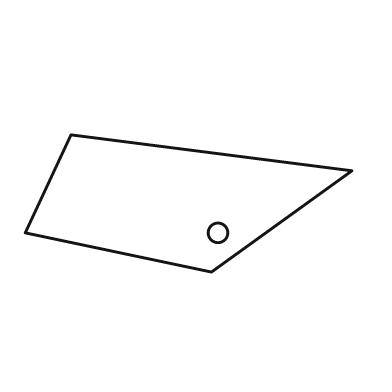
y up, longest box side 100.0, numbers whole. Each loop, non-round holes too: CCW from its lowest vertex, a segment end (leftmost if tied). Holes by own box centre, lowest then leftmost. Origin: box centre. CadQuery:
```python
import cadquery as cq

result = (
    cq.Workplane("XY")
    .moveTo(7.0, -21.0)
    .lineTo(50.0, 10.0)
    .lineTo(-36.0, 21.0)
    .lineTo(-50.0, -9.0)
    .close()
    .moveTo(9.0, -9.0)
    .circle(3.0)
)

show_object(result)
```